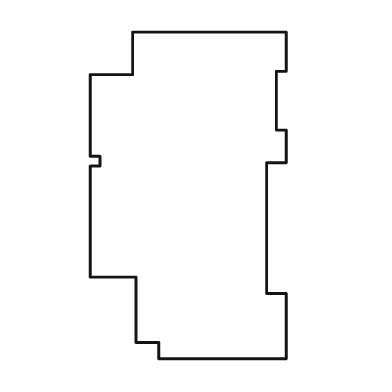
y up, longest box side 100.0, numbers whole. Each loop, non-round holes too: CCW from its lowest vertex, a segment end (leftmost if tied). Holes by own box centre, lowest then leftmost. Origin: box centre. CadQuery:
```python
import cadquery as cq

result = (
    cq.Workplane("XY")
    .moveTo(-9.0, -50.0)
    .lineTo(30.0, -50.0)
    .lineTo(30.0, -30.0)
    .lineTo(24.0, -30.0)
    .lineTo(24.0, 10.0)
    .lineTo(30.0, 10.0)
    .lineTo(30.0, 20.0)
    .lineTo(27.0, 20.0)
    .lineTo(27.0, 38.0)
    .lineTo(30.0, 38.0)
    .lineTo(30.0, 50.0)
    .lineTo(-17.0, 50.0)
    .lineTo(-17.0, 37.0)
    .lineTo(-30.0, 37.0)
    .lineTo(-30.0, 12.0)
    .lineTo(-27.0, 12.0)
    .lineTo(-27.0, 9.0)
    .lineTo(-30.0, 9.0)
    .lineTo(-30.0, -25.0)
    .lineTo(-16.0, -25.0)
    .lineTo(-16.0, -45.0)
    .lineTo(-9.0, -45.0)
    .close()
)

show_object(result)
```